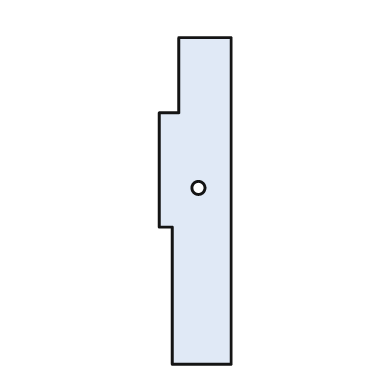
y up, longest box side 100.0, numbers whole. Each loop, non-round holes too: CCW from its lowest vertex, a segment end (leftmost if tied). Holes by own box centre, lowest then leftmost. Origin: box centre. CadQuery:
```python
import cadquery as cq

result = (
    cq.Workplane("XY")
    .moveTo(-7.0, -50.0)
    .lineTo(11.0, -50.0)
    .lineTo(11.0, 50.0)
    .lineTo(-5.0, 50.0)
    .lineTo(-5.0, 27.0)
    .lineTo(-11.0, 27.0)
    .lineTo(-11.0, -8.0)
    .lineTo(-7.0, -8.0)
    .close()
    .moveTo(1.0, 4.0)
    .circle(2.0)
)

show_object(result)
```